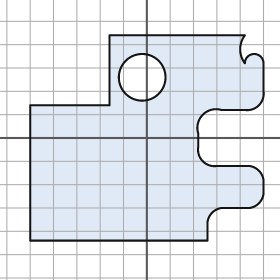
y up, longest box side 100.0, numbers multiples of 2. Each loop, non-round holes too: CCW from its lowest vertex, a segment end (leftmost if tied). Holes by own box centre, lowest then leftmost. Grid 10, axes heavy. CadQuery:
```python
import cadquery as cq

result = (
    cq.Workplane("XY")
    .moveTo(-50.0, -44.0)
    .lineTo(26.0, -44.0)
    .lineTo(26.0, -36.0)
    .threePointArc((28.0, -32.0), (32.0, -30.0))
    .lineTo(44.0, -30.0)
    .threePointArc((48.0, -28.0), (50.0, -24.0))
    .lineTo(50.0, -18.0)
    .threePointArc((48.0, -14.0), (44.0, -12.0))
    .lineTo(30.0, -12.0)
    .threePointArc((24.0, -10.0), (22.0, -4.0))
    .lineTo(22.0, 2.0)
    .threePointArc((24.0, 10.0), (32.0, 12.0))
    .lineTo(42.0, 12.0)
    .threePointArc((48.0, 14.0), (50.0, 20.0))
    .lineTo(50.0, 32.0)
    .threePointArc((46.0, 36.0), (42.0, 32.0))
    .threePointArc((40.0, 38.0), (42.0, 44.0))
    .lineTo(-16.0, 44.0)
    .lineTo(-16.0, 14.0)
    .lineTo(-50.0, 14.0)
    .close()
    .moveTo(-2.0, 26.0)
    .circle(10.0)
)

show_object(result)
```